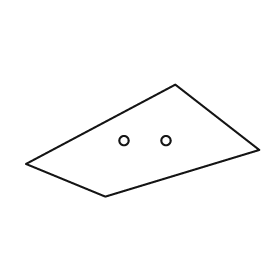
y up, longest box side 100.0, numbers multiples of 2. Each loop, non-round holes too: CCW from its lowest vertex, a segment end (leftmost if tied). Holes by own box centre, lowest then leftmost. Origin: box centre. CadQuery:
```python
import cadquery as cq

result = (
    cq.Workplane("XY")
    .moveTo(-16.0, -24.0)
    .lineTo(50.0, -4.0)
    .lineTo(14.0, 24.0)
    .lineTo(-50.0, -10.0)
    .close()
    .moveTo(-8.0, 0.0)
    .circle(2.0)
    .moveTo(10.0, 0.0)
    .circle(2.0)
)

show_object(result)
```